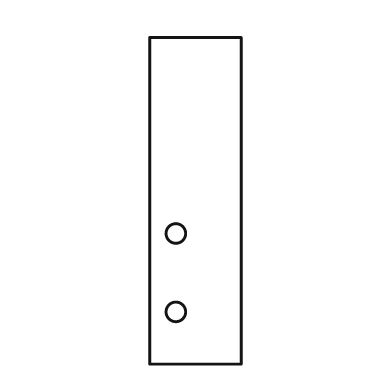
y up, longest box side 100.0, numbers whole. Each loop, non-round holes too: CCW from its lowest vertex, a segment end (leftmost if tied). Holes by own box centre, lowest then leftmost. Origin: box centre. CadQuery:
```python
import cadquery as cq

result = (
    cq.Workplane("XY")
    .moveTo(-14.0, -50.0)
    .lineTo(14.0, -50.0)
    .lineTo(14.0, 50.0)
    .lineTo(-14.0, 50.0)
    .close()
    .moveTo(-6.0, -34.0)
    .circle(3.0)
    .moveTo(-6.0, -10.0)
    .circle(3.0)
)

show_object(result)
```